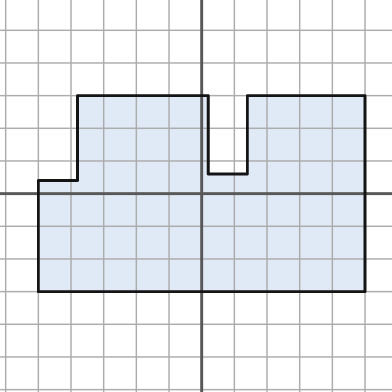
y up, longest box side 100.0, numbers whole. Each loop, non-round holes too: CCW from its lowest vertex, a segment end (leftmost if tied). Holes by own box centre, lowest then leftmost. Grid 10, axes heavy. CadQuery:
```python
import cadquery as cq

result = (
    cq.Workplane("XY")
    .moveTo(-50.0, -30.0)
    .lineTo(50.0, -30.0)
    .lineTo(50.0, 30.0)
    .lineTo(14.0, 30.0)
    .lineTo(14.0, 6.0)
    .lineTo(2.0, 6.0)
    .lineTo(2.0, 30.0)
    .lineTo(-38.0, 30.0)
    .lineTo(-38.0, 4.0)
    .lineTo(-50.0, 4.0)
    .close()
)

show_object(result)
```